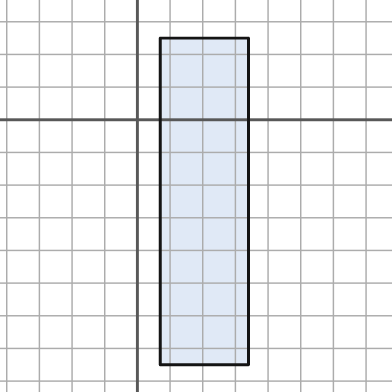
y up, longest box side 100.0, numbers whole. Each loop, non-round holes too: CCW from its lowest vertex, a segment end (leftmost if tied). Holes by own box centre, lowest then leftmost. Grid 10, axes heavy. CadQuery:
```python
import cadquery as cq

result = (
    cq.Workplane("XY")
    .moveTo(7.0, -75.0)
    .lineTo(34.0, -75.0)
    .lineTo(34.0, 25.0)
    .lineTo(7.0, 25.0)
    .close()
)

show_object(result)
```